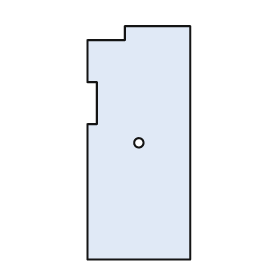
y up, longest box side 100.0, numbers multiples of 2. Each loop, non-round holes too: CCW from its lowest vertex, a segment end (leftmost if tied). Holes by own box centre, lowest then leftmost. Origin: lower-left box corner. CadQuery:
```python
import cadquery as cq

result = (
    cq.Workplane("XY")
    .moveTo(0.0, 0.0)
    .lineTo(44.0, 0.0)
    .lineTo(44.0, 100.0)
    .lineTo(16.0, 100.0)
    .lineTo(16.0, 94.0)
    .lineTo(0.0, 94.0)
    .lineTo(0.0, 76.0)
    .lineTo(4.0, 76.0)
    .lineTo(4.0, 58.0)
    .lineTo(0.0, 58.0)
    .close()
    .moveTo(22.0, 50.0)
    .circle(2.0)
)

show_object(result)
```